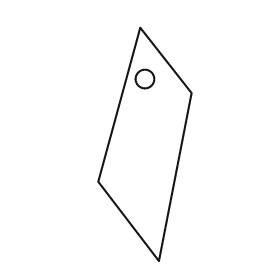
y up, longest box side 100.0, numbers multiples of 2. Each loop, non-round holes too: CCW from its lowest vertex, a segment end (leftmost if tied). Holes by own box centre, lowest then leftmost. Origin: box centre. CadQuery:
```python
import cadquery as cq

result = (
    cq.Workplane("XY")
    .moveTo(6.0, -50.0)
    .lineTo(20.0, 22.0)
    .lineTo(-2.0, 50.0)
    .lineTo(-20.0, -16.0)
    .close()
    .moveTo(0.0, 28.0)
    .circle(4.0)
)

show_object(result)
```